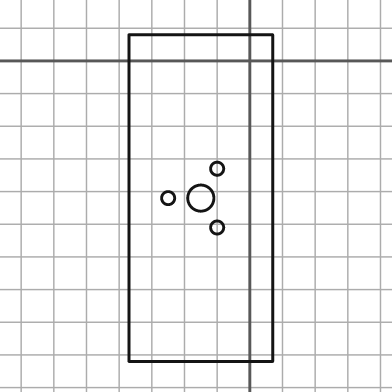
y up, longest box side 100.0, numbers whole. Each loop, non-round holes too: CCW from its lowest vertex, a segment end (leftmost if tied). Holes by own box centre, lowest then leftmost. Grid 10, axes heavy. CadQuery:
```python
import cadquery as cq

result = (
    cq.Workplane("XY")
    .moveTo(-37.0, -92.0)
    .lineTo(7.0, -92.0)
    .lineTo(7.0, 8.0)
    .lineTo(-37.0, 8.0)
    .close()
    .moveTo(-10.0, -51.0)
    .circle(2.0)
    .moveTo(-25.0, -42.0)
    .circle(2.0)
    .moveTo(-15.0, -42.0)
    .circle(4.0)
    .moveTo(-10.0, -33.0)
    .circle(2.0)
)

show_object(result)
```